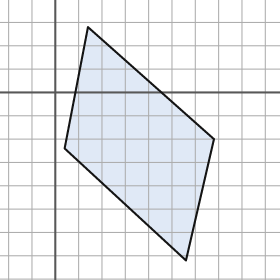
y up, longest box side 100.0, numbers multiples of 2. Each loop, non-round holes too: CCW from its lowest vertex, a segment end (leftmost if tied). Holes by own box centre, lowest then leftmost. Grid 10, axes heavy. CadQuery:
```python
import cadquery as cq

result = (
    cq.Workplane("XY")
    .moveTo(56.0, -72.0)
    .lineTo(68.0, -20.0)
    .lineTo(14.0, 28.0)
    .lineTo(4.0, -24.0)
    .close()
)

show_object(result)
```